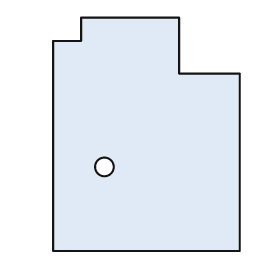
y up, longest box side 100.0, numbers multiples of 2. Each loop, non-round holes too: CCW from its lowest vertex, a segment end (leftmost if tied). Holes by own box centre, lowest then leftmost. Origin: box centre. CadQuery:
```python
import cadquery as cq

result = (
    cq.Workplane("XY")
    .moveTo(-40.0, -50.0)
    .lineTo(40.0, -50.0)
    .lineTo(40.0, 26.0)
    .lineTo(14.0, 26.0)
    .lineTo(14.0, 50.0)
    .lineTo(-28.0, 50.0)
    .lineTo(-28.0, 40.0)
    .lineTo(-40.0, 40.0)
    .close()
    .moveTo(-18.0, -14.0)
    .circle(4.0)
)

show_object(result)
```